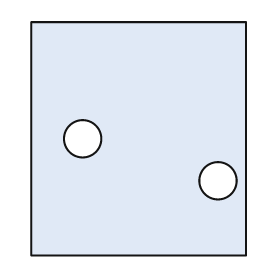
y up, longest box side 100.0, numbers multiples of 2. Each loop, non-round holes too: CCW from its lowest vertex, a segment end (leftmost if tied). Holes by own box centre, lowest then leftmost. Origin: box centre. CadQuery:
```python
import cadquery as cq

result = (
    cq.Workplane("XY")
    .moveTo(-46.0, -50.0)
    .lineTo(46.0, -50.0)
    .lineTo(46.0, 50.0)
    .lineTo(-46.0, 50.0)
    .close()
    .moveTo(34.0, -18.0)
    .circle(8.0)
    .moveTo(-24.0, 0.0)
    .circle(8.0)
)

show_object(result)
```